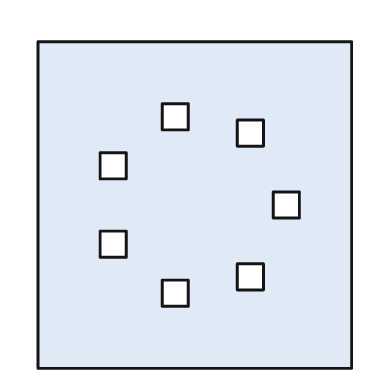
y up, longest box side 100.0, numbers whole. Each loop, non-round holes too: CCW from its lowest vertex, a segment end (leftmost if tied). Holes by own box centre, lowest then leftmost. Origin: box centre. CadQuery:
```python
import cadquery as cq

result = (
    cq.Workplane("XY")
    .moveTo(-48.0, -50.0)
    .lineTo(48.0, -50.0)
    .lineTo(48.0, 50.0)
    .lineTo(-48.0, 50.0)
    .close()
    .moveTo(-10.0, -31.0)
    .lineTo(-2.0, -31.0)
    .lineTo(-2.0, -23.0)
    .lineTo(-10.0, -23.0)
    .close()
    .moveTo(13.0, -26.0)
    .lineTo(21.0, -26.0)
    .lineTo(21.0, -18.0)
    .lineTo(13.0, -18.0)
    .close()
    .moveTo(-29.0, -16.0)
    .lineTo(-21.0, -16.0)
    .lineTo(-21.0, -8.0)
    .lineTo(-29.0, -8.0)
    .close()
    .moveTo(24.0, -4.0)
    .lineTo(32.0, -4.0)
    .lineTo(32.0, 4.0)
    .lineTo(24.0, 4.0)
    .close()
    .moveTo(-29.0, 8.0)
    .lineTo(-21.0, 8.0)
    .lineTo(-21.0, 16.0)
    .lineTo(-29.0, 16.0)
    .close()
    .moveTo(13.0, 18.0)
    .lineTo(21.0, 18.0)
    .lineTo(21.0, 26.0)
    .lineTo(13.0, 26.0)
    .close()
    .moveTo(-10.0, 23.0)
    .lineTo(-2.0, 23.0)
    .lineTo(-2.0, 31.0)
    .lineTo(-10.0, 31.0)
    .close()
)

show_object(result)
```